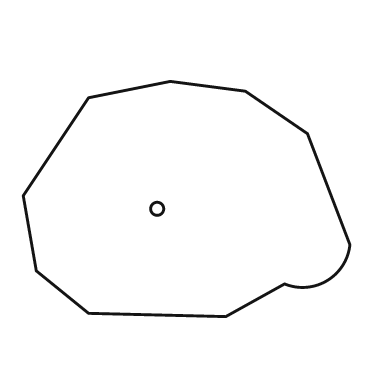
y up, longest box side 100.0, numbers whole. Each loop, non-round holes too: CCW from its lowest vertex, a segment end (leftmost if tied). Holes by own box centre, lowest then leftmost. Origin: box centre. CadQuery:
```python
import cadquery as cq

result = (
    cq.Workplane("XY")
    .moveTo(12.0, -36.0)
    .lineTo(30.0, -26.0)
    .threePointArc((43.0, -25.0), (50.0, -14.0))
    .lineTo(37.0, 20.0)
    .lineTo(18.0, 33.0)
    .lineTo(-5.0, 36.0)
    .lineTo(-30.0, 31.0)
    .lineTo(-50.0, 1.0)
    .lineTo(-46.0, -22.0)
    .lineTo(-30.0, -35.0)
    .close()
    .moveTo(-9.0, -3.0)
    .circle(2.0)
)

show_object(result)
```